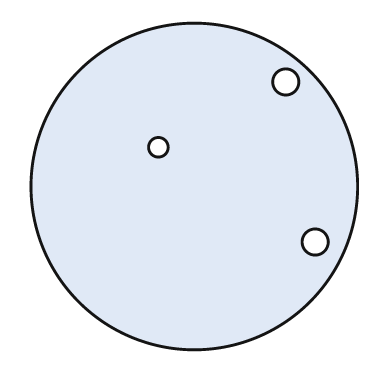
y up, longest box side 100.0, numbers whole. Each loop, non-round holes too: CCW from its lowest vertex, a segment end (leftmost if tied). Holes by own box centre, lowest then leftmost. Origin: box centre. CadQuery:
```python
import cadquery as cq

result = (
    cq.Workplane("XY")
    .moveTo(0.0, 0.0)
    .circle(50.0)
    .moveTo(37.0, -17.0)
    .circle(4.0)
    .moveTo(-11.0, 12.0)
    .circle(3.0)
    .moveTo(28.0, 32.0)
    .circle(4.0)
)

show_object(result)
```